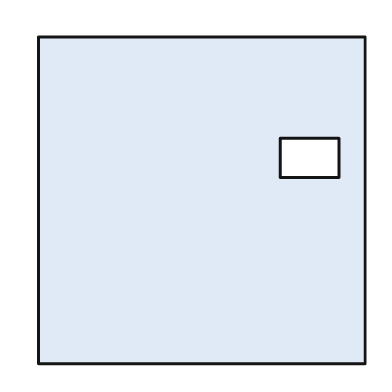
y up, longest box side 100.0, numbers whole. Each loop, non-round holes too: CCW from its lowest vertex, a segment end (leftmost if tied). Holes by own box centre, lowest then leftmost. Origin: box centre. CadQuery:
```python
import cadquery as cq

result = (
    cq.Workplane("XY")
    .moveTo(-50.0, -50.0)
    .lineTo(50.0, -50.0)
    .lineTo(50.0, 50.0)
    .lineTo(-50.0, 50.0)
    .close()
    .moveTo(24.0, 7.0)
    .lineTo(42.0, 7.0)
    .lineTo(42.0, 19.0)
    .lineTo(24.0, 19.0)
    .close()
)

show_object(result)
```